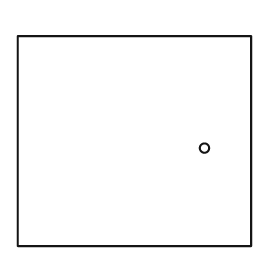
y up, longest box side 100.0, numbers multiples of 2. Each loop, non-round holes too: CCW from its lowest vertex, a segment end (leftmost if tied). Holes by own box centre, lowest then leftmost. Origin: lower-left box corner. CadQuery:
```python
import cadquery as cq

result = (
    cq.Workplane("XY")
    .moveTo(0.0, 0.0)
    .lineTo(100.0, 0.0)
    .lineTo(100.0, 90.0)
    .lineTo(0.0, 90.0)
    .close()
    .moveTo(80.0, 42.0)
    .circle(2.0)
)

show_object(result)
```